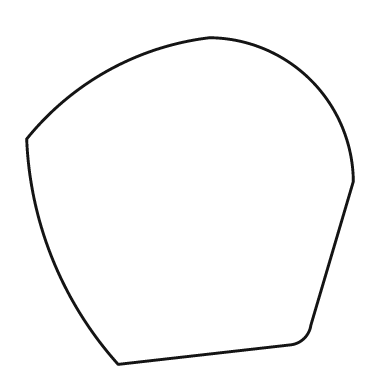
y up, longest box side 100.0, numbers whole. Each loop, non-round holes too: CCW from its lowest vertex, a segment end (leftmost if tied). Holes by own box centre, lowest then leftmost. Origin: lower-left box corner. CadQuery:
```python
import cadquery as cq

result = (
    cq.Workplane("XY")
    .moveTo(28.0, 0.0)
    .lineTo(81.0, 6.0)
    .threePointArc((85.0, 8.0), (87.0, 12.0))
    .lineTo(100.0, 56.0)
    .threePointArc((87.0, 87.0), (56.0, 100.0))
    .threePointArc((25.0, 90.0), (0.0, 69.0))
    .threePointArc((8.0, 32.0), (28.0, 0.0))
    .close()
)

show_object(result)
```